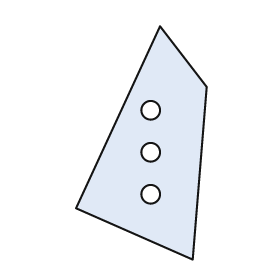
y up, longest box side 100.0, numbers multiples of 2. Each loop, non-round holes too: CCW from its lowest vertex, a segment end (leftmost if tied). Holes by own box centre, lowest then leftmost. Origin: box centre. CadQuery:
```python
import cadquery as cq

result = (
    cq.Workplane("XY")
    .moveTo(22.0, -50.0)
    .lineTo(28.0, 24.0)
    .lineTo(8.0, 50.0)
    .lineTo(-28.0, -28.0)
    .close()
    .moveTo(4.0, -22.0)
    .circle(4.0)
    .moveTo(4.0, -4.0)
    .circle(4.0)
    .moveTo(4.0, 14.0)
    .circle(4.0)
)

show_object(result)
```